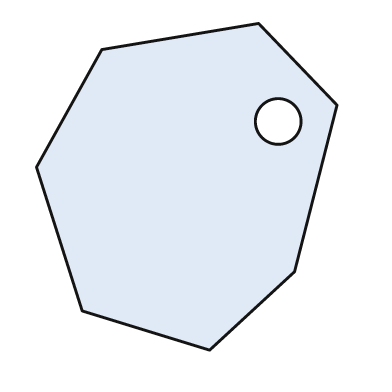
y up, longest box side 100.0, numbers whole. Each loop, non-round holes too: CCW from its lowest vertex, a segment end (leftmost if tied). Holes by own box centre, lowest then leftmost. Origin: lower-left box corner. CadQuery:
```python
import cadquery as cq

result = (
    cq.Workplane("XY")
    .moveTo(53.0, 0.0)
    .lineTo(79.0, 24.0)
    .lineTo(92.0, 75.0)
    .lineTo(68.0, 100.0)
    .lineTo(20.0, 92.0)
    .lineTo(0.0, 56.0)
    .lineTo(14.0, 12.0)
    .close()
    .moveTo(74.0, 70.0)
    .circle(7.0)
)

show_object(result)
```